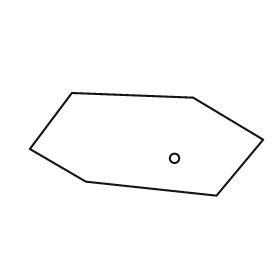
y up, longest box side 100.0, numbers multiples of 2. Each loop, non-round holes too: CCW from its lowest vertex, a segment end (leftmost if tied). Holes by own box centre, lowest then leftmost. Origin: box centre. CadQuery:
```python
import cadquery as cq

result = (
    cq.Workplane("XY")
    .moveTo(30.0, -22.0)
    .lineTo(50.0, 2.0)
    .lineTo(20.0, 20.0)
    .lineTo(-32.0, 22.0)
    .lineTo(-50.0, -2.0)
    .lineTo(-26.0, -16.0)
    .close()
    .moveTo(12.0, -6.0)
    .circle(2.0)
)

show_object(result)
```